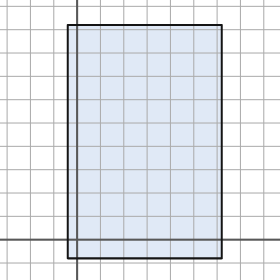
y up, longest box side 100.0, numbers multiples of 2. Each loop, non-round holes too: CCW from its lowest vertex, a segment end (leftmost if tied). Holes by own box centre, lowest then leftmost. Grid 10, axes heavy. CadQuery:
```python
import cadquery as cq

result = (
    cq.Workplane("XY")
    .moveTo(-4.0, -8.0)
    .lineTo(62.0, -8.0)
    .lineTo(62.0, 92.0)
    .lineTo(-4.0, 92.0)
    .close()
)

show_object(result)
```